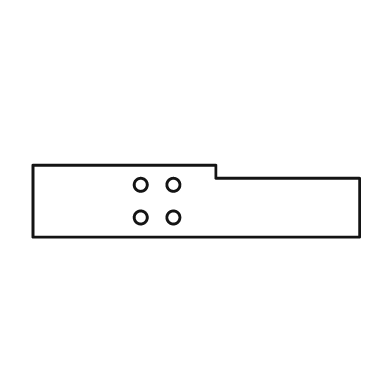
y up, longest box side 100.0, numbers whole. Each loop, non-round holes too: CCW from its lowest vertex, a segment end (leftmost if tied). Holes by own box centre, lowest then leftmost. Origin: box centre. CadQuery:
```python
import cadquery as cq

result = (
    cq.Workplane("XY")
    .moveTo(-50.0, -11.0)
    .lineTo(50.0, -11.0)
    .lineTo(50.0, 7.0)
    .lineTo(6.0, 7.0)
    .lineTo(6.0, 11.0)
    .lineTo(-50.0, 11.0)
    .close()
    .moveTo(-17.0, -5.0)
    .circle(2.0)
    .moveTo(-7.0, -5.0)
    .circle(2.0)
    .moveTo(-17.0, 5.0)
    .circle(2.0)
    .moveTo(-7.0, 5.0)
    .circle(2.0)
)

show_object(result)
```